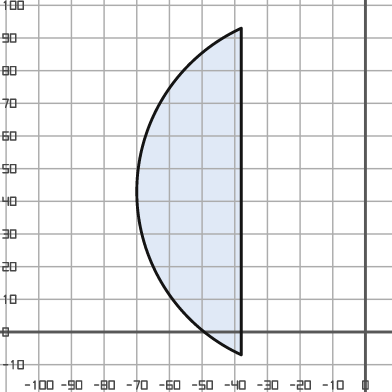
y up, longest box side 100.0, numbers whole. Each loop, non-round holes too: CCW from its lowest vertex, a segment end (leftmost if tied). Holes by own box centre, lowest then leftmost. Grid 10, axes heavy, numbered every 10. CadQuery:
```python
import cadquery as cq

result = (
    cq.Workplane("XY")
    .moveTo(-38.0, -7.0)
    .lineTo(-38.0, 93.0)
    .threePointArc((-70.0, 43.0), (-38.0, -7.0))
    .close()
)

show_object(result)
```